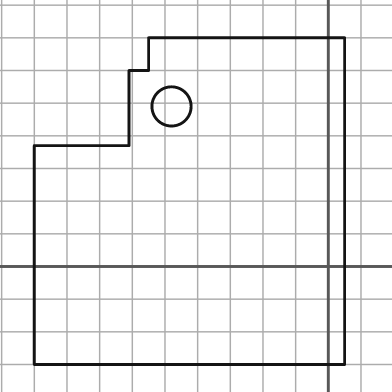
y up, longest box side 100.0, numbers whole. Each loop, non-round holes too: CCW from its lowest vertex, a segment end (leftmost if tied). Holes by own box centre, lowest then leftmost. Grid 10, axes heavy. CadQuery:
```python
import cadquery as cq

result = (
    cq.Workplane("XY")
    .moveTo(-90.0, -30.0)
    .lineTo(5.0, -30.0)
    .lineTo(5.0, 70.0)
    .lineTo(-55.0, 70.0)
    .lineTo(-55.0, 60.0)
    .lineTo(-61.0, 60.0)
    .lineTo(-61.0, 37.0)
    .lineTo(-90.0, 37.0)
    .close()
    .moveTo(-48.0, 49.0)
    .circle(6.0)
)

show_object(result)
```